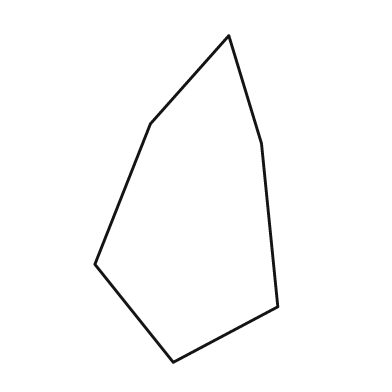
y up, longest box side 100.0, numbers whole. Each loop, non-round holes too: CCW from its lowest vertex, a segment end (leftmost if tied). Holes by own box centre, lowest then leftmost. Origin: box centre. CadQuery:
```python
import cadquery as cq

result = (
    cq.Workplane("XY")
    .moveTo(-4.0, -50.0)
    .lineTo(28.0, -33.0)
    .lineTo(23.0, 17.0)
    .lineTo(13.0, 50.0)
    .lineTo(-11.0, 23.0)
    .lineTo(-28.0, -20.0)
    .close()
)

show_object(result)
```